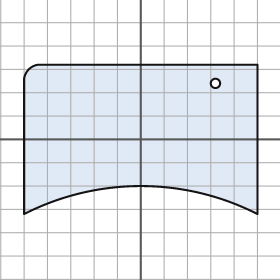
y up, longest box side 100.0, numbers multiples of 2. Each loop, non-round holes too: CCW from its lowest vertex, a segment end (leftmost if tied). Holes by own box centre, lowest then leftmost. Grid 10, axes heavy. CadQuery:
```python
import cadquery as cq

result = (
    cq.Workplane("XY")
    .moveTo(-50.0, -32.0)
    .threePointArc((0.0, -20.0), (50.0, -32.0))
    .lineTo(50.0, 32.0)
    .lineTo(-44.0, 32.0)
    .threePointArc((-48.0, 30.0), (-50.0, 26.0))
    .close()
    .moveTo(32.0, 24.0)
    .circle(2.0)
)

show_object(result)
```